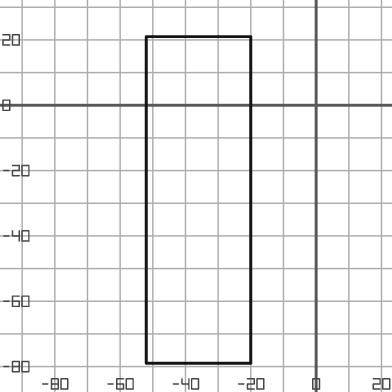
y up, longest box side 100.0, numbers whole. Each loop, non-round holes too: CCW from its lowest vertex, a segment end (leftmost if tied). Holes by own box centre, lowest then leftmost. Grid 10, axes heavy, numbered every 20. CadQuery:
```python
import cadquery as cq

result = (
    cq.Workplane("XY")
    .moveTo(-52.0, -79.0)
    .lineTo(-20.0, -79.0)
    .lineTo(-20.0, 21.0)
    .lineTo(-52.0, 21.0)
    .close()
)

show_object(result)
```